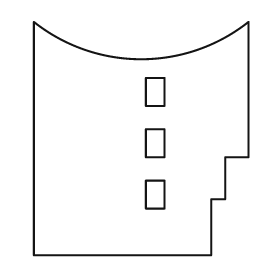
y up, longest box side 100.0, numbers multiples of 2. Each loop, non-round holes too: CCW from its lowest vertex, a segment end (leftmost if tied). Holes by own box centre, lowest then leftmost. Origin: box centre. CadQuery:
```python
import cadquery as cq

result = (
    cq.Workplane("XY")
    .moveTo(-46.0, -50.0)
    .lineTo(30.0, -50.0)
    .lineTo(30.0, -26.0)
    .lineTo(36.0, -26.0)
    .lineTo(36.0, -8.0)
    .lineTo(46.0, -8.0)
    .lineTo(46.0, 50.0)
    .threePointArc((0.0, 34.0), (-46.0, 50.0))
    .close()
    .moveTo(2.0, -30.0)
    .lineTo(10.0, -30.0)
    .lineTo(10.0, -18.0)
    .lineTo(2.0, -18.0)
    .close()
    .moveTo(2.0, -8.0)
    .lineTo(10.0, -8.0)
    .lineTo(10.0, 4.0)
    .lineTo(2.0, 4.0)
    .close()
    .moveTo(2.0, 14.0)
    .lineTo(10.0, 14.0)
    .lineTo(10.0, 26.0)
    .lineTo(2.0, 26.0)
    .close()
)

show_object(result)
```